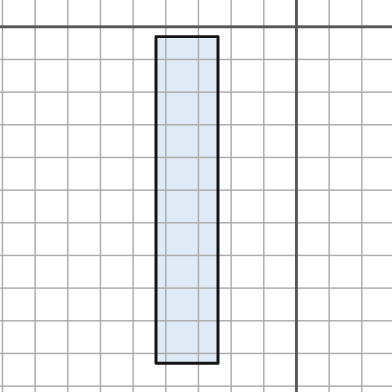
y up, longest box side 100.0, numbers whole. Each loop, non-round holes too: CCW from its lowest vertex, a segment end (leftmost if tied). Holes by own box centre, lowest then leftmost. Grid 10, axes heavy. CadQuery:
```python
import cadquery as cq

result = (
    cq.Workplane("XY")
    .moveTo(-43.0, -103.0)
    .lineTo(-24.0, -103.0)
    .lineTo(-24.0, -3.0)
    .lineTo(-43.0, -3.0)
    .close()
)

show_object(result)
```